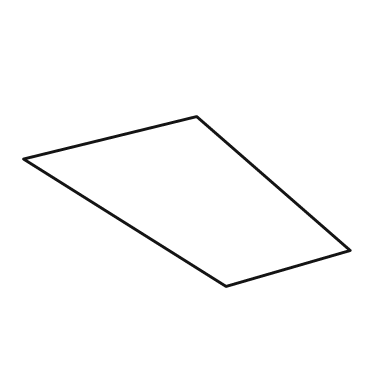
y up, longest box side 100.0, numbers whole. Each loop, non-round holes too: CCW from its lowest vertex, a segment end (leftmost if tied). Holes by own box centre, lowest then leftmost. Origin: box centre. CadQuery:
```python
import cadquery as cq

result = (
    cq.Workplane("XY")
    .moveTo(12.0, -26.0)
    .lineTo(50.0, -15.0)
    .lineTo(3.0, 26.0)
    .lineTo(-50.0, 13.0)
    .close()
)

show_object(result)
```